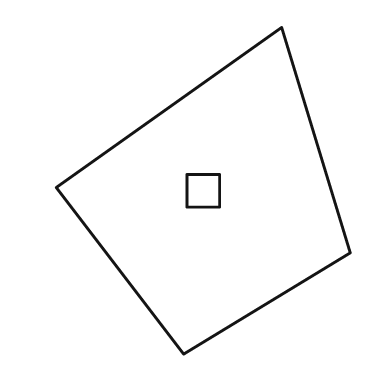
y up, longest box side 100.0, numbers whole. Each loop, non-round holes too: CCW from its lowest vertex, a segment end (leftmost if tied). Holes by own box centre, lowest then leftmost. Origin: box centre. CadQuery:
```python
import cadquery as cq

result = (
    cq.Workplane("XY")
    .moveTo(-6.0, -50.0)
    .lineTo(45.0, -19.0)
    .lineTo(24.0, 50.0)
    .lineTo(-45.0, 1.0)
    .close()
    .moveTo(-5.0, -5.0)
    .lineTo(5.0, -5.0)
    .lineTo(5.0, 5.0)
    .lineTo(-5.0, 5.0)
    .close()
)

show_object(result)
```